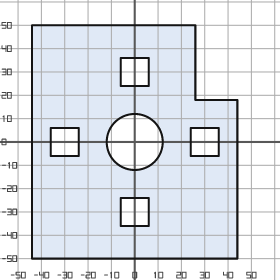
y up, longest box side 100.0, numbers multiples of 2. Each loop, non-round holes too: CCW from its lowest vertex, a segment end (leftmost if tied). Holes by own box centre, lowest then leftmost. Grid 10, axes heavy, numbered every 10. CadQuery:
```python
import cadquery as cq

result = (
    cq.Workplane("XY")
    .moveTo(-44.0, -50.0)
    .lineTo(44.0, -50.0)
    .lineTo(44.0, 18.0)
    .lineTo(26.0, 18.0)
    .lineTo(26.0, 50.0)
    .lineTo(-44.0, 50.0)
    .close()
    .moveTo(-6.0, -36.0)
    .lineTo(6.0, -36.0)
    .lineTo(6.0, -24.0)
    .lineTo(-6.0, -24.0)
    .close()
    .moveTo(-36.0, -6.0)
    .lineTo(-24.0, -6.0)
    .lineTo(-24.0, 6.0)
    .lineTo(-36.0, 6.0)
    .close()
    .moveTo(0.0, 0.0)
    .circle(12.0)
    .moveTo(24.0, -6.0)
    .lineTo(36.0, -6.0)
    .lineTo(36.0, 6.0)
    .lineTo(24.0, 6.0)
    .close()
    .moveTo(-6.0, 24.0)
    .lineTo(6.0, 24.0)
    .lineTo(6.0, 36.0)
    .lineTo(-6.0, 36.0)
    .close()
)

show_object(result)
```